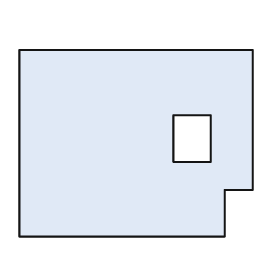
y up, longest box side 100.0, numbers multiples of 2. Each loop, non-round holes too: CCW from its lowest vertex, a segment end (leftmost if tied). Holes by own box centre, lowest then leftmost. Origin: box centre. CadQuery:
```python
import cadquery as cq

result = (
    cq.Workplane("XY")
    .moveTo(-50.0, -40.0)
    .lineTo(38.0, -40.0)
    .lineTo(38.0, -20.0)
    .lineTo(50.0, -20.0)
    .lineTo(50.0, 40.0)
    .lineTo(-50.0, 40.0)
    .close()
    .moveTo(16.0, -8.0)
    .lineTo(32.0, -8.0)
    .lineTo(32.0, 12.0)
    .lineTo(16.0, 12.0)
    .close()
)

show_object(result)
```